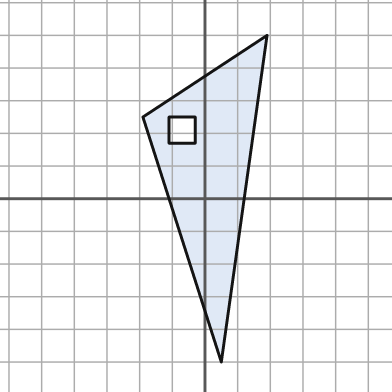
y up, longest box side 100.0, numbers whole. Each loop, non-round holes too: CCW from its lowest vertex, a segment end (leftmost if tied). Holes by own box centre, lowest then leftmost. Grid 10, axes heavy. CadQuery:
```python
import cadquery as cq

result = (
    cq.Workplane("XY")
    .moveTo(5.0, -50.0)
    .lineTo(19.0, 50.0)
    .lineTo(-19.0, 25.0)
    .close()
    .moveTo(-11.0, 17.0)
    .lineTo(-3.0, 17.0)
    .lineTo(-3.0, 25.0)
    .lineTo(-11.0, 25.0)
    .close()
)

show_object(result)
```